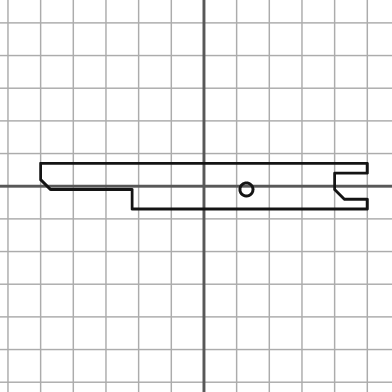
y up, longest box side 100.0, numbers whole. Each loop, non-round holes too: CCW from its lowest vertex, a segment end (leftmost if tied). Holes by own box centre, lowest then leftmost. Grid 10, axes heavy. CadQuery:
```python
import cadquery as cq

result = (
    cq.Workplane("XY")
    .moveTo(-22.0, -7.0)
    .lineTo(50.0, -7.0)
    .lineTo(50.0, -4.0)
    .lineTo(43.0, -4.0)
    .lineTo(40.0, -1.0)
    .lineTo(40.0, 4.0)
    .lineTo(50.0, 4.0)
    .lineTo(50.0, 7.0)
    .lineTo(-50.0, 7.0)
    .lineTo(-50.0, 2.0)
    .lineTo(-47.0, -1.0)
    .lineTo(-22.0, -1.0)
    .close()
    .moveTo(13.0, -1.0)
    .circle(2.0)
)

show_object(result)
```